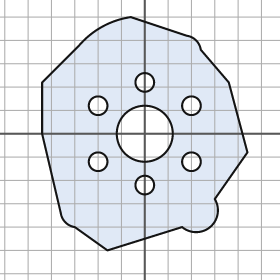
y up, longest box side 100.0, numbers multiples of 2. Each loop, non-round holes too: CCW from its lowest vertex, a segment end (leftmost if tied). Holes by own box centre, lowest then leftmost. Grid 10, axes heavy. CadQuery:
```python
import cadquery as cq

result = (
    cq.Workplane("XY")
    .moveTo(-16.0, -50.0)
    .lineTo(16.0, -40.0)
    .threePointArc((28.0, -40.0), (30.0, -28.0))
    .lineTo(44.0, -8.0)
    .lineTo(36.0, 22.0)
    .lineTo(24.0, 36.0)
    .threePointArc((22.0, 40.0), (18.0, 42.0))
    .lineTo(-6.0, 50.0)
    .threePointArc((-18.0, 46.0), (-28.0, 38.0))
    .lineTo(-44.0, 22.0)
    .lineTo(-44.0, 0.0)
    .lineTo(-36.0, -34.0)
    .threePointArc((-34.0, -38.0), (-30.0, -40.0))
    .close()
    .moveTo(0.0, -22.0)
    .circle(4.0)
    .moveTo(-20.0, -12.0)
    .circle(4.0)
    .moveTo(20.0, -12.0)
    .circle(4.0)
    .moveTo(0.0, 0.0)
    .circle(12.0)
    .moveTo(-20.0, 12.0)
    .circle(4.0)
    .moveTo(20.0, 12.0)
    .circle(4.0)
    .moveTo(0.0, 22.0)
    .circle(4.0)
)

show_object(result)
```